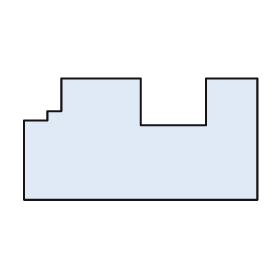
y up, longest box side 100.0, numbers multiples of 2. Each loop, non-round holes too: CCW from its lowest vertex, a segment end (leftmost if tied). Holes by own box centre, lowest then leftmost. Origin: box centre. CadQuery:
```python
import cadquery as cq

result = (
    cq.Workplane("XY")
    .moveTo(-50.0, -26.0)
    .lineTo(50.0, -26.0)
    .lineTo(50.0, 26.0)
    .lineTo(28.0, 26.0)
    .lineTo(28.0, 6.0)
    .lineTo(0.0, 6.0)
    .lineTo(0.0, 26.0)
    .lineTo(-34.0, 26.0)
    .lineTo(-34.0, 12.0)
    .lineTo(-40.0, 12.0)
    .lineTo(-40.0, 8.0)
    .lineTo(-50.0, 8.0)
    .close()
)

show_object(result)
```